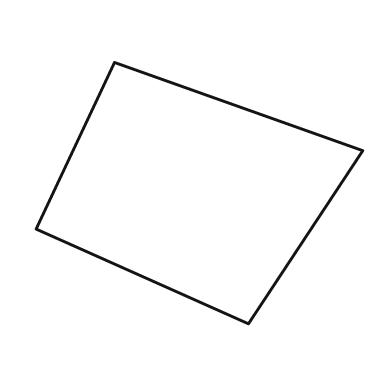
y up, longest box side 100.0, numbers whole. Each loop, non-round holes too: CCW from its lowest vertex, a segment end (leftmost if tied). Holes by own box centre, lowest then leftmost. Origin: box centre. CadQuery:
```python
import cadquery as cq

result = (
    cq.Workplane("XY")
    .moveTo(15.0, -40.0)
    .lineTo(50.0, 13.0)
    .lineTo(-26.0, 40.0)
    .lineTo(-50.0, -11.0)
    .close()
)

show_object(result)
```